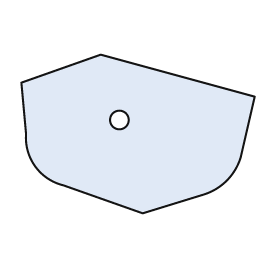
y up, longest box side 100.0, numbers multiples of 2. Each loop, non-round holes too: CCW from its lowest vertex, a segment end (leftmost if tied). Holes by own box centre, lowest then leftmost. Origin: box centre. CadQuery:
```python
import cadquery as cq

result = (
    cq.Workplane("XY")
    .moveTo(2.0, -34.0)
    .lineTo(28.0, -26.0)
    .threePointArc((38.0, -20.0), (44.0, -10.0))
    .lineTo(50.0, 16.0)
    .lineTo(-16.0, 34.0)
    .lineTo(-50.0, 22.0)
    .lineTo(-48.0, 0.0)
    .threePointArc((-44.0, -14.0), (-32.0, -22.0))
    .close()
    .moveTo(-8.0, 6.0)
    .circle(4.0)
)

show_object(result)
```